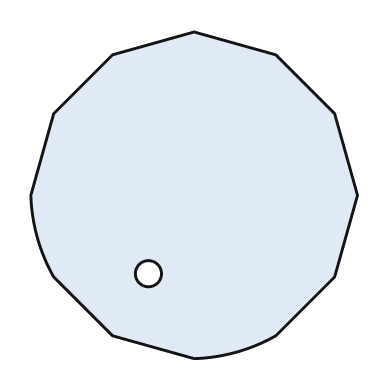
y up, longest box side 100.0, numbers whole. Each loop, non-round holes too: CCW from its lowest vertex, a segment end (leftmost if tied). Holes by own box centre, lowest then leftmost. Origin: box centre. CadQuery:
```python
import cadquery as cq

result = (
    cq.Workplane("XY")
    .moveTo(0.0, -50.0)
    .threePointArc((13.0, -48.0), (25.0, -43.0))
    .lineTo(43.0, -25.0)
    .lineTo(50.0, 0.0)
    .lineTo(43.0, 25.0)
    .lineTo(25.0, 43.0)
    .lineTo(0.0, 50.0)
    .lineTo(-25.0, 43.0)
    .lineTo(-43.0, 25.0)
    .lineTo(-50.0, 0.0)
    .threePointArc((-48.0, -13.0), (-43.0, -25.0))
    .lineTo(-25.0, -43.0)
    .close()
    .moveTo(-14.0, -24.0)
    .circle(4.0)
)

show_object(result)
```